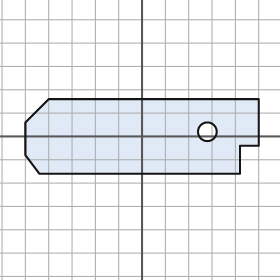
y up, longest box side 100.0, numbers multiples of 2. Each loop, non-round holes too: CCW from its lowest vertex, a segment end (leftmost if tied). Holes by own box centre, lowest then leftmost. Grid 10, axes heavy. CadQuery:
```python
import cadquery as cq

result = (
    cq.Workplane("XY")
    .moveTo(-44.0, -16.0)
    .lineTo(42.0, -16.0)
    .lineTo(42.0, -4.0)
    .lineTo(50.0, -4.0)
    .lineTo(50.0, 16.0)
    .lineTo(-40.0, 16.0)
    .lineTo(-50.0, 6.0)
    .lineTo(-50.0, -8.0)
    .close()
    .moveTo(28.0, 2.0)
    .circle(4.0)
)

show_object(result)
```